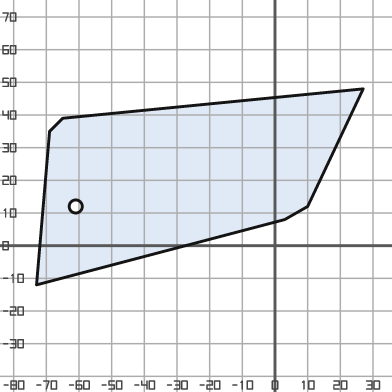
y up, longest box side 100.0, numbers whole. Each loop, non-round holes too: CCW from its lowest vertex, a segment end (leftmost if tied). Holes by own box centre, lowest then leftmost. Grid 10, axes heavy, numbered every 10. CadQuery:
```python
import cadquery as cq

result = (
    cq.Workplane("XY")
    .moveTo(-73.0, -12.0)
    .lineTo(3.0, 8.0)
    .lineTo(10.0, 12.0)
    .lineTo(27.0, 48.0)
    .lineTo(-65.0, 39.0)
    .lineTo(-69.0, 35.0)
    .close()
    .moveTo(-61.0, 12.0)
    .circle(2.0)
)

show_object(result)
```